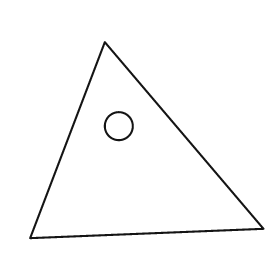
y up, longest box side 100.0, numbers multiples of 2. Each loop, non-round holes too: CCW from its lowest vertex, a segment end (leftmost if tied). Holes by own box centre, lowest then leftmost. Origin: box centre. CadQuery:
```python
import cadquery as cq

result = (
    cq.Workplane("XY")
    .moveTo(-50.0, -42.0)
    .lineTo(50.0, -38.0)
    .lineTo(-18.0, 42.0)
    .close()
    .moveTo(-12.0, 6.0)
    .circle(6.0)
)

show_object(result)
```